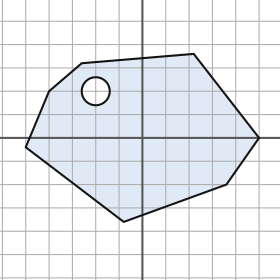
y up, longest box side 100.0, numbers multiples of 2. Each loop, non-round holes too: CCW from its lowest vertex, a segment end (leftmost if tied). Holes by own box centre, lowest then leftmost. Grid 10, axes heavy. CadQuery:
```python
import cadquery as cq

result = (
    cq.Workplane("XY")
    .moveTo(-8.0, -36.0)
    .lineTo(36.0, -20.0)
    .lineTo(50.0, 0.0)
    .lineTo(22.0, 36.0)
    .lineTo(-26.0, 32.0)
    .lineTo(-40.0, 20.0)
    .lineTo(-50.0, -4.0)
    .close()
    .moveTo(-20.0, 20.0)
    .circle(6.0)
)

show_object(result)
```